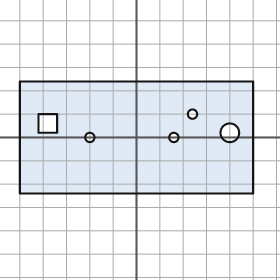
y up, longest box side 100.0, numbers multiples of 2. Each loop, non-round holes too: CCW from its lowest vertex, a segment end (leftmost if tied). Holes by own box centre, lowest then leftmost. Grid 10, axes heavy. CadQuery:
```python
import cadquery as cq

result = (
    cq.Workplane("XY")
    .moveTo(-50.0, -24.0)
    .lineTo(50.0, -24.0)
    .lineTo(50.0, 24.0)
    .lineTo(-50.0, 24.0)
    .close()
    .moveTo(-20.0, 0.0)
    .circle(2.0)
    .moveTo(16.0, 0.0)
    .circle(2.0)
    .moveTo(40.0, 2.0)
    .circle(4.0)
    .moveTo(-42.0, 2.0)
    .lineTo(-34.0, 2.0)
    .lineTo(-34.0, 10.0)
    .lineTo(-42.0, 10.0)
    .close()
    .moveTo(24.0, 10.0)
    .circle(2.0)
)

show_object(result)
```